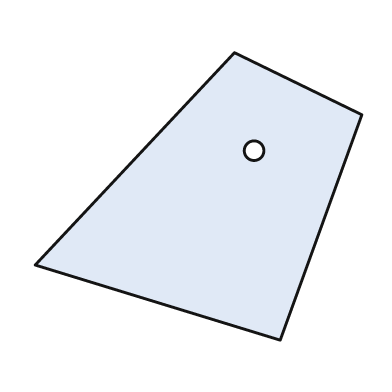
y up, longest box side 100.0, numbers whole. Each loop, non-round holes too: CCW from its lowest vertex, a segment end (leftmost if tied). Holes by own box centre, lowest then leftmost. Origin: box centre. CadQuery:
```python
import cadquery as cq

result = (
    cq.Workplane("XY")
    .moveTo(25.0, -44.0)
    .lineTo(50.0, 25.0)
    .lineTo(11.0, 44.0)
    .lineTo(-50.0, -21.0)
    .close()
    .moveTo(17.0, 14.0)
    .circle(3.0)
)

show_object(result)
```